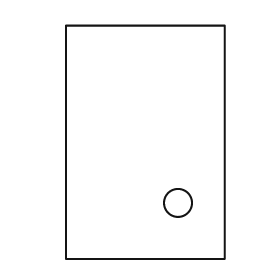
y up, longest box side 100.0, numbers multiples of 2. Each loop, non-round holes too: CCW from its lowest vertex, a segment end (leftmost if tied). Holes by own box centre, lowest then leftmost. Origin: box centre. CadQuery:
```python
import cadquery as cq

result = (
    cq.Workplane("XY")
    .moveTo(-34.0, -50.0)
    .lineTo(34.0, -50.0)
    .lineTo(34.0, 50.0)
    .lineTo(-34.0, 50.0)
    .close()
    .moveTo(14.0, -26.0)
    .circle(6.0)
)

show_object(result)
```